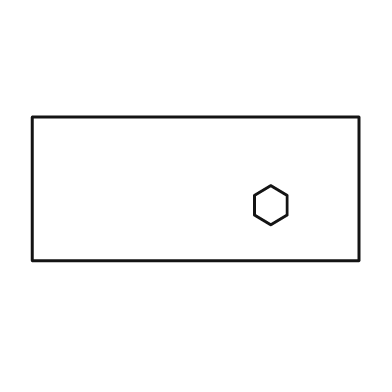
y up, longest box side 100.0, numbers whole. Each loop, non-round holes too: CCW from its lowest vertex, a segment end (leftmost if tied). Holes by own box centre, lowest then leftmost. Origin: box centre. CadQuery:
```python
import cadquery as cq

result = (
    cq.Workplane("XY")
    .moveTo(-50.0, -22.0)
    .lineTo(50.0, -22.0)
    .lineTo(50.0, 22.0)
    .lineTo(-50.0, 22.0)
    .close()
    .moveTo(23.0, -11.0)
    .lineTo(28.0, -8.0)
    .lineTo(28.0, -2.0)
    .lineTo(23.0, 1.0)
    .lineTo(18.0, -2.0)
    .lineTo(18.0, -8.0)
    .close()
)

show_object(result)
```